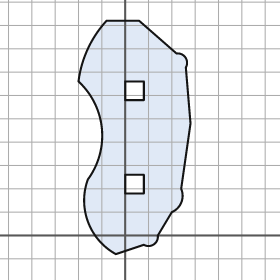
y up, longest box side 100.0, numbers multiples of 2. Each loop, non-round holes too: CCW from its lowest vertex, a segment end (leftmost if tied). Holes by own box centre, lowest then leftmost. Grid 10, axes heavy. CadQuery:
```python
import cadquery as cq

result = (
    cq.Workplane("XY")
    .moveTo(-4.0, -8.0)
    .lineTo(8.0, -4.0)
    .threePointArc((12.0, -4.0), (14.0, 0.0))
    .lineTo(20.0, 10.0)
    .threePointArc((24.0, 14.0), (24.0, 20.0))
    .lineTo(28.0, 48.0)
    .lineTo(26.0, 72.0)
    .threePointArc((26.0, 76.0), (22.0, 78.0))
    .lineTo(6.0, 92.0)
    .lineTo(-8.0, 92.0)
    .threePointArc((-16.0, 80.0), (-20.0, 66.0))
    .threePointArc((-10.0, 46.0), (-16.0, 24.0))
    .threePointArc((-16.0, 6.0), (-4.0, -8.0))
    .close()
    .moveTo(0.0, 18.0)
    .lineTo(8.0, 18.0)
    .lineTo(8.0, 26.0)
    .lineTo(0.0, 26.0)
    .close()
    .moveTo(0.0, 58.0)
    .lineTo(8.0, 58.0)
    .lineTo(8.0, 66.0)
    .lineTo(0.0, 66.0)
    .close()
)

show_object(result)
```